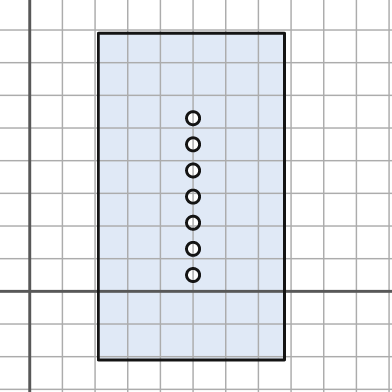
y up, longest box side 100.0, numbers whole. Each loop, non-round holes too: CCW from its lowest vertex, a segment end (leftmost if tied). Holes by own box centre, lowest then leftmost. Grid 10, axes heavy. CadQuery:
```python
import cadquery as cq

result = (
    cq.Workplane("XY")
    .moveTo(21.0, -21.0)
    .lineTo(78.0, -21.0)
    .lineTo(78.0, 79.0)
    .lineTo(21.0, 79.0)
    .close()
    .moveTo(50.0, 5.0)
    .circle(2.0)
    .moveTo(50.0, 13.0)
    .circle(2.0)
    .moveTo(50.0, 21.0)
    .circle(2.0)
    .moveTo(50.0, 29.0)
    .circle(2.0)
    .moveTo(50.0, 37.0)
    .circle(2.0)
    .moveTo(50.0, 45.0)
    .circle(2.0)
    .moveTo(50.0, 53.0)
    .circle(2.0)
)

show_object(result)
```